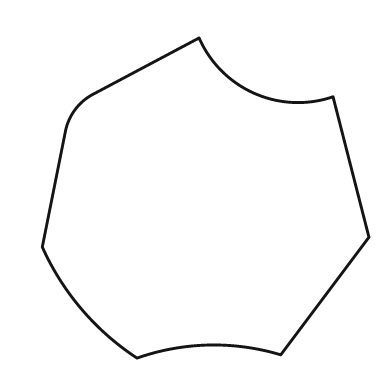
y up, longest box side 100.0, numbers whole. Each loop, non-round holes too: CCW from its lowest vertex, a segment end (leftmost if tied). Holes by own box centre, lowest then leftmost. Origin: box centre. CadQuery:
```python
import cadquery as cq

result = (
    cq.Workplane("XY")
    .moveTo(-21.0, -49.0)
    .threePointArc((1.0, -45.0), (23.0, -48.0))
    .lineTo(50.0, -12.0)
    .lineTo(39.0, 31.0)
    .threePointArc((15.0, 32.0), (-2.0, 49.0))
    .lineTo(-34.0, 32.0)
    .threePointArc((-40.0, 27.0), (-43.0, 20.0))
    .lineTo(-50.0, -15.0)
    .threePointArc((-38.0, -34.0), (-21.0, -49.0))
    .close()
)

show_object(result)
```